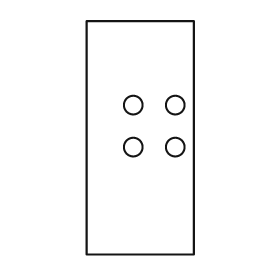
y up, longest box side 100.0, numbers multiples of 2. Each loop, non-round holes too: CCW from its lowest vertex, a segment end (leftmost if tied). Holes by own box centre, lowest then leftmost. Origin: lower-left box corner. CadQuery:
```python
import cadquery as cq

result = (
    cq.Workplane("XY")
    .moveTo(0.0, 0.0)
    .lineTo(46.0, 0.0)
    .lineTo(46.0, 100.0)
    .lineTo(0.0, 100.0)
    .close()
    .moveTo(20.0, 46.0)
    .circle(4.0)
    .moveTo(38.0, 46.0)
    .circle(4.0)
    .moveTo(20.0, 64.0)
    .circle(4.0)
    .moveTo(38.0, 64.0)
    .circle(4.0)
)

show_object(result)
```